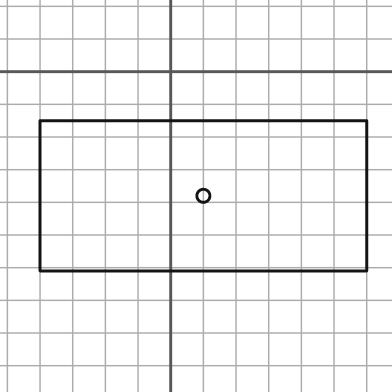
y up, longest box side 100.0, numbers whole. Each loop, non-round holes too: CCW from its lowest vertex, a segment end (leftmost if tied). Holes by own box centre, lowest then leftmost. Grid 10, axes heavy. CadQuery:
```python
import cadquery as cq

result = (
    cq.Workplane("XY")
    .moveTo(-40.0, -61.0)
    .lineTo(60.0, -61.0)
    .lineTo(60.0, -15.0)
    .lineTo(-40.0, -15.0)
    .close()
    .moveTo(10.0, -38.0)
    .circle(2.0)
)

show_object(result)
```